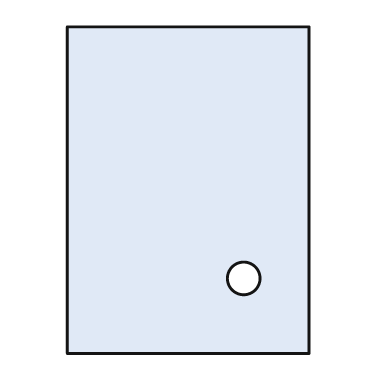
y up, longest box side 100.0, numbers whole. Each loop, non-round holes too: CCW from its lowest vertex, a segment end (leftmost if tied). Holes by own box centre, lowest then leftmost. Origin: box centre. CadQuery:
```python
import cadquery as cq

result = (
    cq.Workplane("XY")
    .moveTo(-37.0, -50.0)
    .lineTo(37.0, -50.0)
    .lineTo(37.0, 50.0)
    .lineTo(-37.0, 50.0)
    .close()
    .moveTo(17.0, -27.0)
    .circle(5.0)
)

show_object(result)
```